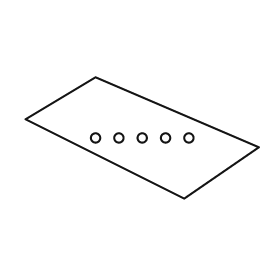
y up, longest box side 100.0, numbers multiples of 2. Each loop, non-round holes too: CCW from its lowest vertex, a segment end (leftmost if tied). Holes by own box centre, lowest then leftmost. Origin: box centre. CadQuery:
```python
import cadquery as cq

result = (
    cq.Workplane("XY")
    .moveTo(18.0, -26.0)
    .lineTo(50.0, -4.0)
    .lineTo(-20.0, 26.0)
    .lineTo(-50.0, 8.0)
    .close()
    .moveTo(-20.0, 0.0)
    .circle(2.0)
    .moveTo(-10.0, 0.0)
    .circle(2.0)
    .moveTo(0.0, 0.0)
    .circle(2.0)
    .moveTo(10.0, 0.0)
    .circle(2.0)
    .moveTo(20.0, 0.0)
    .circle(2.0)
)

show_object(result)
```